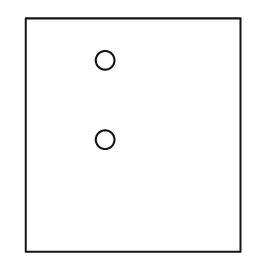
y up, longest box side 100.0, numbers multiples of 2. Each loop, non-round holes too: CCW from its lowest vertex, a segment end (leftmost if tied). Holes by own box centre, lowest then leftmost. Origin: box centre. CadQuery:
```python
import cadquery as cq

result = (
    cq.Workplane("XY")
    .moveTo(-46.0, -50.0)
    .lineTo(46.0, -50.0)
    .lineTo(46.0, 50.0)
    .lineTo(-46.0, 50.0)
    .close()
    .moveTo(-12.0, -2.0)
    .circle(4.0)
    .moveTo(-12.0, 32.0)
    .circle(4.0)
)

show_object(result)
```